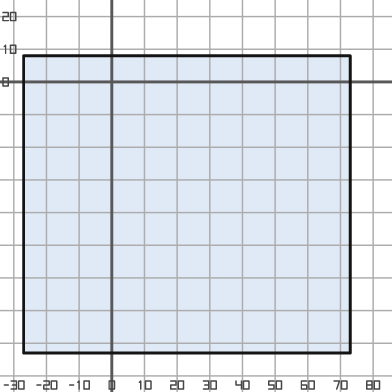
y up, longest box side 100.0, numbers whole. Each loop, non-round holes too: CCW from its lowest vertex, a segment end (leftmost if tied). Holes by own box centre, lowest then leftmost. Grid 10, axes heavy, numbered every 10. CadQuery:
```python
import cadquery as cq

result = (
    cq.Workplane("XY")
    .moveTo(-27.0, -83.0)
    .lineTo(73.0, -83.0)
    .lineTo(73.0, 8.0)
    .lineTo(-27.0, 8.0)
    .close()
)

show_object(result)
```